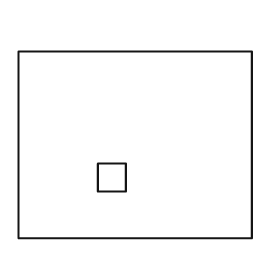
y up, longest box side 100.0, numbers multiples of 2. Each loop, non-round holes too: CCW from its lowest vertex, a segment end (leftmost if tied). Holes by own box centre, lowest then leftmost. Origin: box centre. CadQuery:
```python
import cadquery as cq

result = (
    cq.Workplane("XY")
    .moveTo(-50.0, -40.0)
    .lineTo(50.0, -40.0)
    .lineTo(50.0, 40.0)
    .lineTo(-50.0, 40.0)
    .close()
    .moveTo(-16.0, -20.0)
    .lineTo(-4.0, -20.0)
    .lineTo(-4.0, -8.0)
    .lineTo(-16.0, -8.0)
    .close()
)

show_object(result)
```